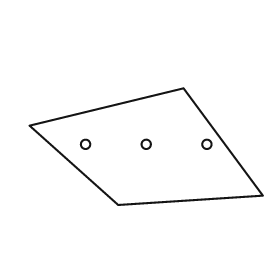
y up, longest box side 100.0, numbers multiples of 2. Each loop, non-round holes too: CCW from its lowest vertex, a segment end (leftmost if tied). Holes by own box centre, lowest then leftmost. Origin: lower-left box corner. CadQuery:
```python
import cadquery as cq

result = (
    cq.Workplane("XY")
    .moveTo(38.0, 0.0)
    .lineTo(100.0, 4.0)
    .lineTo(66.0, 50.0)
    .lineTo(0.0, 34.0)
    .close()
    .moveTo(24.0, 26.0)
    .circle(2.0)
    .moveTo(50.0, 26.0)
    .circle(2.0)
    .moveTo(76.0, 26.0)
    .circle(2.0)
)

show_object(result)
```